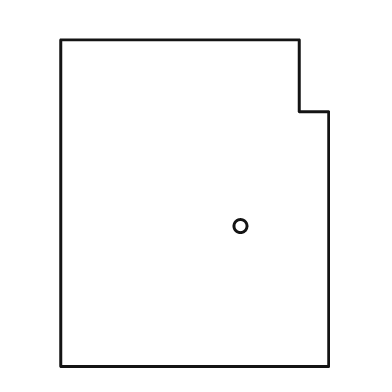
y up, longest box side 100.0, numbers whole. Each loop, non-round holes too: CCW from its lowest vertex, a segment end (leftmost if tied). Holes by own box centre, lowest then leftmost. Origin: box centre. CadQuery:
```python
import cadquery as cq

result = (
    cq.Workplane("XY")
    .moveTo(-41.0, -50.0)
    .lineTo(41.0, -50.0)
    .lineTo(41.0, 28.0)
    .lineTo(32.0, 28.0)
    .lineTo(32.0, 50.0)
    .lineTo(-41.0, 50.0)
    .close()
    .moveTo(14.0, -7.0)
    .circle(2.0)
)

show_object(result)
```